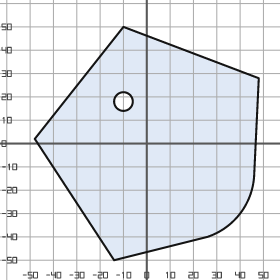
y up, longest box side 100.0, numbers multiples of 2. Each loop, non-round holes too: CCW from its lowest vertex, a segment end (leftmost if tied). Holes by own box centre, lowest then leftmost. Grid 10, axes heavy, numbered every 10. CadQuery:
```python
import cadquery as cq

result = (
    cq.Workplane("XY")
    .moveTo(-14.0, -50.0)
    .lineTo(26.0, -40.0)
    .threePointArc((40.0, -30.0), (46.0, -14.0))
    .lineTo(48.0, 28.0)
    .lineTo(-10.0, 50.0)
    .lineTo(-48.0, 2.0)
    .close()
    .moveTo(-10.0, 18.0)
    .circle(4.0)
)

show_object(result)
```